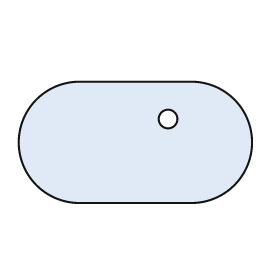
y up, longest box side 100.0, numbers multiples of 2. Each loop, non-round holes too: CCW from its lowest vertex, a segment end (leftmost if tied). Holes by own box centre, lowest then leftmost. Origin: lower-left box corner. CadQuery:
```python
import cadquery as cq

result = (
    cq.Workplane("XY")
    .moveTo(26.0, 0.0)
    .lineTo(74.0, 0.0)
    .threePointArc((100.0, 26.0), (74.0, 52.0))
    .lineTo(26.0, 52.0)
    .threePointArc((0.0, 26.0), (26.0, 0.0))
    .close()
    .moveTo(64.0, 36.0)
    .circle(4.0)
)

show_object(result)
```